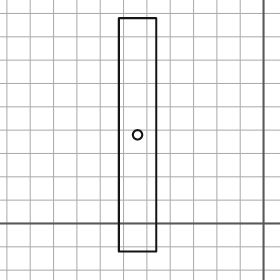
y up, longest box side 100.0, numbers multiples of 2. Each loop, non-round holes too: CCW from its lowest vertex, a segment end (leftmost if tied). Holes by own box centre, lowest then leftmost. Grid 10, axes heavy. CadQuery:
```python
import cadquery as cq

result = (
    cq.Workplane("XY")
    .moveTo(-62.0, -12.0)
    .lineTo(-46.0, -12.0)
    .lineTo(-46.0, 88.0)
    .lineTo(-62.0, 88.0)
    .close()
    .moveTo(-54.0, 38.0)
    .circle(2.0)
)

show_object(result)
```